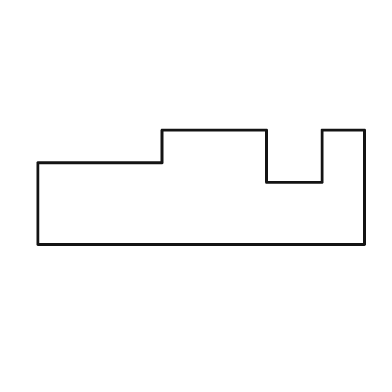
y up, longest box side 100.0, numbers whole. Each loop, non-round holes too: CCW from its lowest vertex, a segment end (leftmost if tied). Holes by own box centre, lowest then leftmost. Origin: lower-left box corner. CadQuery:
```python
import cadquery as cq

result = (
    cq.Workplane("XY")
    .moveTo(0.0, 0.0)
    .lineTo(100.0, 0.0)
    .lineTo(100.0, 35.0)
    .lineTo(87.0, 35.0)
    .lineTo(87.0, 19.0)
    .lineTo(70.0, 19.0)
    .lineTo(70.0, 35.0)
    .lineTo(38.0, 35.0)
    .lineTo(38.0, 25.0)
    .lineTo(0.0, 25.0)
    .close()
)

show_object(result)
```